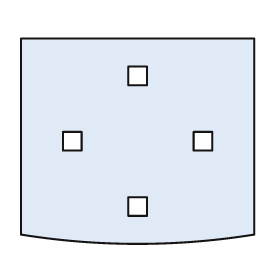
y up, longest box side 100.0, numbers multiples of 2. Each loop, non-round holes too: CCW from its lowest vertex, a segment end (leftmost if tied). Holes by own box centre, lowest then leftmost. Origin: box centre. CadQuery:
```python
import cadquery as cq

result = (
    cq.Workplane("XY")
    .moveTo(-50.0, -40.0)
    .threePointArc((0.0, -44.0), (50.0, -40.0))
    .lineTo(50.0, 44.0)
    .lineTo(-50.0, 44.0)
    .close()
    .moveTo(-4.0, -32.0)
    .lineTo(4.0, -32.0)
    .lineTo(4.0, -24.0)
    .lineTo(-4.0, -24.0)
    .close()
    .moveTo(-32.0, -4.0)
    .lineTo(-24.0, -4.0)
    .lineTo(-24.0, 4.0)
    .lineTo(-32.0, 4.0)
    .close()
    .moveTo(24.0, -4.0)
    .lineTo(32.0, -4.0)
    .lineTo(32.0, 4.0)
    .lineTo(24.0, 4.0)
    .close()
    .moveTo(-4.0, 24.0)
    .lineTo(4.0, 24.0)
    .lineTo(4.0, 32.0)
    .lineTo(-4.0, 32.0)
    .close()
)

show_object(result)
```